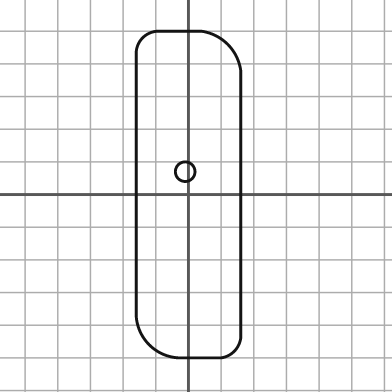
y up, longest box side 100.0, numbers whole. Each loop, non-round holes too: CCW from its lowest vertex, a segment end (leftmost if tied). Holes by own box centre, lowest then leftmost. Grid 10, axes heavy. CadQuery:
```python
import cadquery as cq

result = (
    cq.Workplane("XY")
    .moveTo(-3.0, -50.0)
    .lineTo(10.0, -50.0)
    .threePointArc((14.0, -48.0), (16.0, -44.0))
    .lineTo(16.0, 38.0)
    .threePointArc((12.0, 46.0), (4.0, 50.0))
    .lineTo(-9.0, 50.0)
    .threePointArc((-14.0, 48.0), (-16.0, 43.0))
    .lineTo(-16.0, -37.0)
    .threePointArc((-12.0, -46.0), (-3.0, -50.0))
    .close()
    .moveTo(-1.0, 7.0)
    .circle(3.0)
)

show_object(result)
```